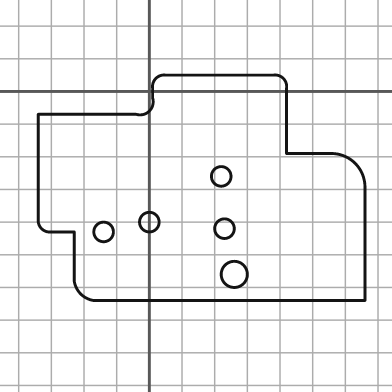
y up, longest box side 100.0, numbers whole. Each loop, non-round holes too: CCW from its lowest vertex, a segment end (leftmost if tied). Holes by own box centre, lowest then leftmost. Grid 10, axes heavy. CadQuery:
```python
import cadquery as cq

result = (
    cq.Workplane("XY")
    .moveTo(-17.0, -64.0)
    .lineTo(66.0, -64.0)
    .lineTo(66.0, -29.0)
    .threePointArc((63.0, -22.0), (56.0, -19.0))
    .lineTo(42.0, -19.0)
    .lineTo(42.0, 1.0)
    .threePointArc((41.0, 4.0), (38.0, 5.0))
    .lineTo(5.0, 5.0)
    .threePointArc((2.0, 4.0), (1.0, 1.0))
    .lineTo(1.0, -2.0)
    .threePointArc((0.0, -6.0), (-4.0, -7.0))
    .lineTo(-34.0, -7.0)
    .lineTo(-34.0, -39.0)
    .threePointArc((-33.0, -42.0), (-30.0, -43.0))
    .lineTo(-23.0, -43.0)
    .lineTo(-23.0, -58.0)
    .threePointArc((-21.0, -62.0), (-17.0, -64.0))
    .close()
    .moveTo(26.0, -56.0)
    .circle(4.0)
    .moveTo(-14.0, -43.0)
    .circle(3.0)
    .moveTo(23.0, -42.0)
    .circle(3.0)
    .moveTo(0.0, -40.0)
    .circle(3.0)
    .moveTo(22.0, -26.0)
    .circle(3.0)
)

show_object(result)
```